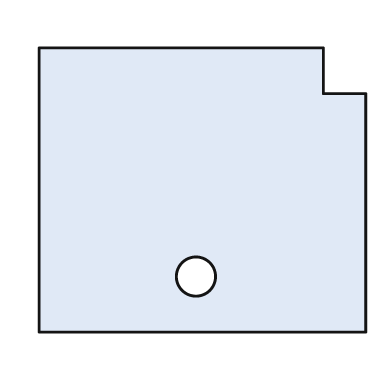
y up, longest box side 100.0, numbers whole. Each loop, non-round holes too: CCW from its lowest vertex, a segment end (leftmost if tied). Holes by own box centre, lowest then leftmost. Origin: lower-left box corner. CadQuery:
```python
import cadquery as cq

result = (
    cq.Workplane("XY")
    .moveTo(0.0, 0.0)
    .lineTo(100.0, 0.0)
    .lineTo(100.0, 73.0)
    .lineTo(87.0, 73.0)
    .lineTo(87.0, 87.0)
    .lineTo(0.0, 87.0)
    .close()
    .moveTo(48.0, 17.0)
    .circle(6.0)
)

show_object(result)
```